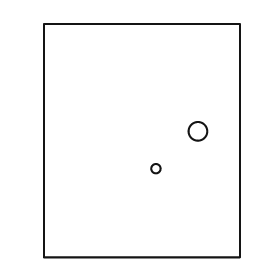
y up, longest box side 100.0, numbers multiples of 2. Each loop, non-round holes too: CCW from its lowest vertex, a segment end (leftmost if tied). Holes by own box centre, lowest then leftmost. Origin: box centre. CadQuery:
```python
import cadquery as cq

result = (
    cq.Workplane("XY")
    .moveTo(-42.0, -50.0)
    .lineTo(42.0, -50.0)
    .lineTo(42.0, 50.0)
    .lineTo(-42.0, 50.0)
    .close()
    .moveTo(6.0, -12.0)
    .circle(2.0)
    .moveTo(24.0, 4.0)
    .circle(4.0)
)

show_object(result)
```